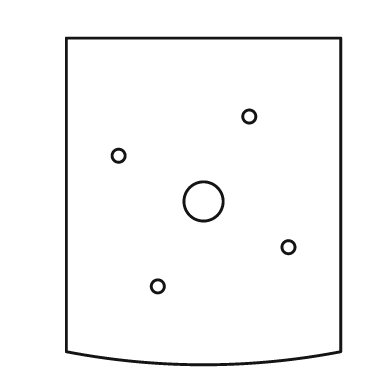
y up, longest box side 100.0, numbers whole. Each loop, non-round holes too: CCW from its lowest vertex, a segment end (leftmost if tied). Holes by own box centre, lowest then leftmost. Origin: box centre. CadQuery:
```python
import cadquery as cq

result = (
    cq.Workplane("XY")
    .moveTo(-42.0, -46.0)
    .threePointArc((0.0, -50.0), (42.0, -46.0))
    .lineTo(42.0, 50.0)
    .lineTo(-42.0, 50.0)
    .close()
    .moveTo(-14.0, -26.0)
    .circle(2.0)
    .moveTo(26.0, -14.0)
    .circle(2.0)
    .moveTo(0.0, 0.0)
    .circle(6.0)
    .moveTo(-26.0, 14.0)
    .circle(2.0)
    .moveTo(14.0, 26.0)
    .circle(2.0)
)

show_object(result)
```